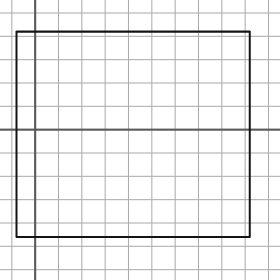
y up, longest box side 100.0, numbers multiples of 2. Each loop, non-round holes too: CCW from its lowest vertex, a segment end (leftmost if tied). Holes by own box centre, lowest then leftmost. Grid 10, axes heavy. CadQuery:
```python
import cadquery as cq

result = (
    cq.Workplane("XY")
    .moveTo(-8.0, -46.0)
    .lineTo(92.0, -46.0)
    .lineTo(92.0, 42.0)
    .lineTo(-8.0, 42.0)
    .close()
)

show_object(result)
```